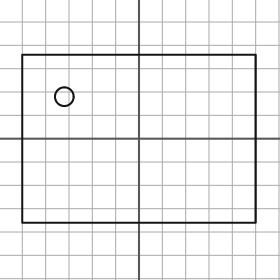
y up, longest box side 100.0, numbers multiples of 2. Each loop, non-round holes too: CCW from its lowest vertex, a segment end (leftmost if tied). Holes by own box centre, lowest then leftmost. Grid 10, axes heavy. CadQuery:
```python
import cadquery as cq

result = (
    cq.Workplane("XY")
    .moveTo(-50.0, -36.0)
    .lineTo(50.0, -36.0)
    .lineTo(50.0, 36.0)
    .lineTo(-50.0, 36.0)
    .close()
    .moveTo(-32.0, 18.0)
    .circle(4.0)
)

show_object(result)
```